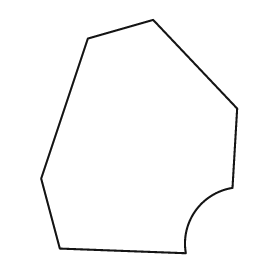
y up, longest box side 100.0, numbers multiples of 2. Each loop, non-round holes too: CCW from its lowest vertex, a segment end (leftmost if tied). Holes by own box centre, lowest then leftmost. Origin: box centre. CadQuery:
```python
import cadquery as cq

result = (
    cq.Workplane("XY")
    .moveTo(20.0, -50.0)
    .threePointArc((24.0, -32.0), (40.0, -22.0))
    .lineTo(42.0, 12.0)
    .lineTo(6.0, 50.0)
    .lineTo(-22.0, 42.0)
    .lineTo(-42.0, -18.0)
    .lineTo(-34.0, -48.0)
    .close()
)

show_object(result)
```